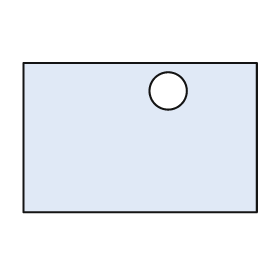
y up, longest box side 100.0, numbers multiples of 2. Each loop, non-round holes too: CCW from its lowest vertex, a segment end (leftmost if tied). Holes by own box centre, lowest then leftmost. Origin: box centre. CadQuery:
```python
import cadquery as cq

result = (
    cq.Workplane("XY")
    .moveTo(-50.0, -32.0)
    .lineTo(50.0, -32.0)
    .lineTo(50.0, 32.0)
    .lineTo(-50.0, 32.0)
    .close()
    .moveTo(12.0, 20.0)
    .circle(8.0)
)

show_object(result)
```